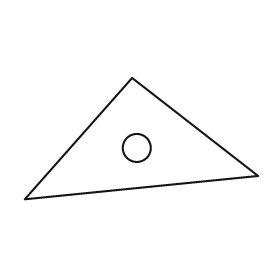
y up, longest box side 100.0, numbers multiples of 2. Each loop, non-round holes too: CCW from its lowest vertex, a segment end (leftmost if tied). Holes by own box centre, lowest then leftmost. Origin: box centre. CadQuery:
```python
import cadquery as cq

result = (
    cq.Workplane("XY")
    .moveTo(-50.0, -26.0)
    .lineTo(50.0, -16.0)
    .lineTo(-4.0, 26.0)
    .close()
    .moveTo(-2.0, -4.0)
    .circle(6.0)
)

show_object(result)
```